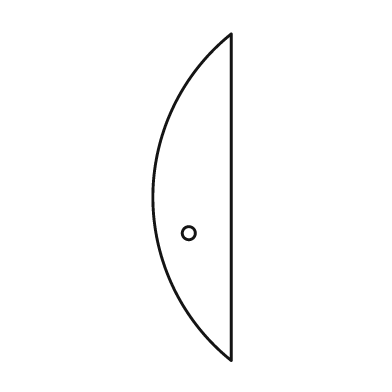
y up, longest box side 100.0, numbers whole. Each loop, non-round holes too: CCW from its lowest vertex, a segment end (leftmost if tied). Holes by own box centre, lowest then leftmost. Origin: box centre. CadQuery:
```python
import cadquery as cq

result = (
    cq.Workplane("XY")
    .moveTo(12.0, -50.0)
    .lineTo(12.0, 50.0)
    .threePointArc((-12.0, 0.0), (12.0, -50.0))
    .close()
    .moveTo(-1.0, -11.0)
    .circle(2.0)
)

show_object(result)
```